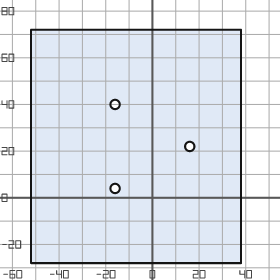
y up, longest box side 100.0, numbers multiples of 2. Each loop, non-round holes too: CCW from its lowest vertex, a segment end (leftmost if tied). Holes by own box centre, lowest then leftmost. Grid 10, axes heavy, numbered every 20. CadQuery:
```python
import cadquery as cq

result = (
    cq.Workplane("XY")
    .moveTo(-52.0, -28.0)
    .lineTo(38.0, -28.0)
    .lineTo(38.0, 72.0)
    .lineTo(-52.0, 72.0)
    .close()
    .moveTo(-16.0, 4.0)
    .circle(2.0)
    .moveTo(16.0, 22.0)
    .circle(2.0)
    .moveTo(-16.0, 40.0)
    .circle(2.0)
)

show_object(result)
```